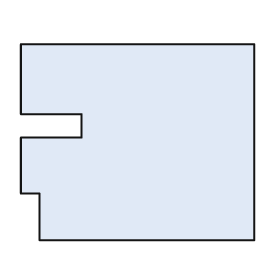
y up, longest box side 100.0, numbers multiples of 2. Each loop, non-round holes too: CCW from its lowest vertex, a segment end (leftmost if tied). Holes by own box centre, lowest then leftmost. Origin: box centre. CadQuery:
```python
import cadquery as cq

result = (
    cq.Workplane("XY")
    .moveTo(-42.0, -42.0)
    .lineTo(50.0, -42.0)
    .lineTo(50.0, 42.0)
    .lineTo(-50.0, 42.0)
    .lineTo(-50.0, 12.0)
    .lineTo(-24.0, 12.0)
    .lineTo(-24.0, 2.0)
    .lineTo(-50.0, 2.0)
    .lineTo(-50.0, -22.0)
    .lineTo(-42.0, -22.0)
    .close()
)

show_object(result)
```